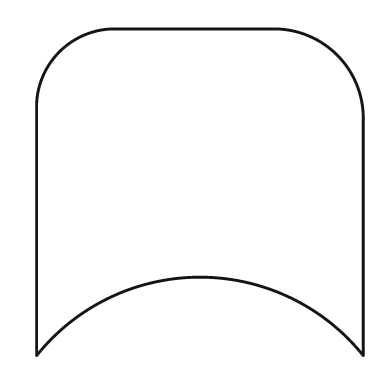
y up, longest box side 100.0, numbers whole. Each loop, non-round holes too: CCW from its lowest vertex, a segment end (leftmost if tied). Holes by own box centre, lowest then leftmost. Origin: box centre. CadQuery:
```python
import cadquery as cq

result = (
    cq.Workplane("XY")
    .moveTo(-50.0, -50.0)
    .threePointArc((0.0, -26.0), (50.0, -50.0))
    .lineTo(50.0, 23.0)
    .threePointArc((42.0, 42.0), (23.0, 50.0))
    .lineTo(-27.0, 50.0)
    .threePointArc((-43.0, 43.0), (-50.0, 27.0))
    .close()
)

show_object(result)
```